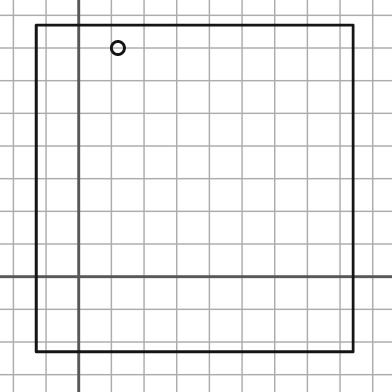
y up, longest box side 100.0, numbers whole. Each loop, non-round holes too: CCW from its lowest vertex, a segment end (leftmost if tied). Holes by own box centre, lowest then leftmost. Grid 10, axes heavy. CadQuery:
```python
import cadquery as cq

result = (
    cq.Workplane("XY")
    .moveTo(-13.0, -23.0)
    .lineTo(84.0, -23.0)
    .lineTo(84.0, 77.0)
    .lineTo(-13.0, 77.0)
    .close()
    .moveTo(12.0, 70.0)
    .circle(2.0)
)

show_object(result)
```